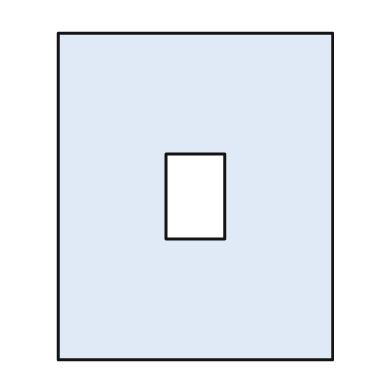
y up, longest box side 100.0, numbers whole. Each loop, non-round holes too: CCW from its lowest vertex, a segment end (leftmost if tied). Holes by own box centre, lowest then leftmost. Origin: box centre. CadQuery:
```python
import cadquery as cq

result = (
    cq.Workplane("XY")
    .moveTo(-42.0, -50.0)
    .lineTo(42.0, -50.0)
    .lineTo(42.0, 50.0)
    .lineTo(-42.0, 50.0)
    .close()
    .moveTo(-9.0, -13.0)
    .lineTo(9.0, -13.0)
    .lineTo(9.0, 13.0)
    .lineTo(-9.0, 13.0)
    .close()
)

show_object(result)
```